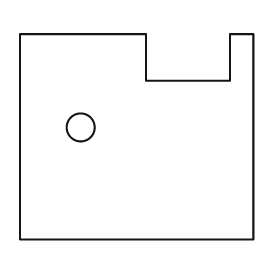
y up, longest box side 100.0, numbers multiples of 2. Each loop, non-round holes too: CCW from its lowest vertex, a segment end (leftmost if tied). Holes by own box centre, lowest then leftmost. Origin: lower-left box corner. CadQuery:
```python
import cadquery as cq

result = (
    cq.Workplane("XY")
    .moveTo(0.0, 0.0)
    .lineTo(100.0, 0.0)
    .lineTo(100.0, 88.0)
    .lineTo(90.0, 88.0)
    .lineTo(90.0, 68.0)
    .lineTo(54.0, 68.0)
    .lineTo(54.0, 88.0)
    .lineTo(0.0, 88.0)
    .close()
    .moveTo(26.0, 48.0)
    .circle(6.0)
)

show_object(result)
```